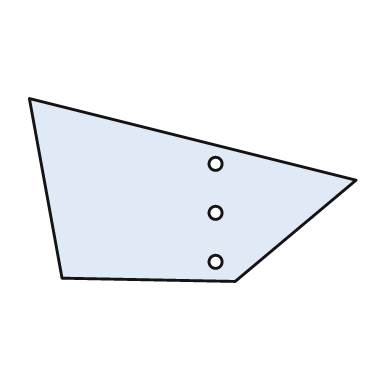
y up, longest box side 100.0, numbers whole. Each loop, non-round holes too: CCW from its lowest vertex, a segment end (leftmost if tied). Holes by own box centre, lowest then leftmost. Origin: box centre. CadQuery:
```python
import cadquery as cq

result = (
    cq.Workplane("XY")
    .moveTo(13.0, -28.0)
    .lineTo(50.0, 3.0)
    .lineTo(-50.0, 28.0)
    .lineTo(-40.0, -27.0)
    .close()
    .moveTo(7.0, -22.0)
    .circle(2.0)
    .moveTo(7.0, -7.0)
    .circle(2.0)
    .moveTo(7.0, 8.0)
    .circle(2.0)
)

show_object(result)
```